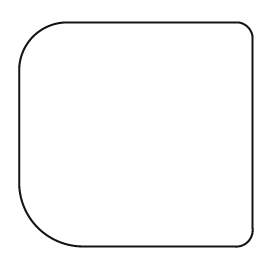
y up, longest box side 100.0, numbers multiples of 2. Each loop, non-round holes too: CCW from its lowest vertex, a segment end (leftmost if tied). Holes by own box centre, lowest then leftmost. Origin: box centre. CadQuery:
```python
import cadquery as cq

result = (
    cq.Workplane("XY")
    .moveTo(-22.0, -48.0)
    .lineTo(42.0, -48.0)
    .threePointArc((48.0, -46.0), (50.0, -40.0))
    .lineTo(50.0, 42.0)
    .threePointArc((48.0, 46.0), (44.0, 48.0))
    .lineTo(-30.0, 48.0)
    .threePointArc((-44.0, 42.0), (-50.0, 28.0))
    .lineTo(-50.0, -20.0)
    .threePointArc((-42.0, -40.0), (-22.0, -48.0))
    .close()
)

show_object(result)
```